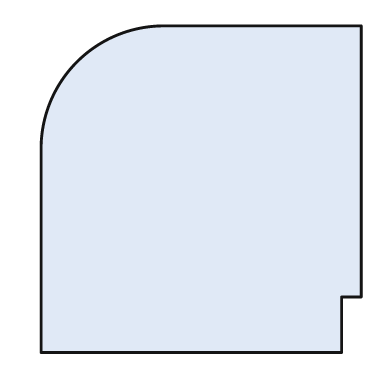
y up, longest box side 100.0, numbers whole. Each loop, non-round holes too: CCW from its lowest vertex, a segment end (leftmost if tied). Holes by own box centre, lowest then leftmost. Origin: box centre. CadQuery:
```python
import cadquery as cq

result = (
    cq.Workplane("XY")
    .moveTo(-49.0, -50.0)
    .lineTo(43.0, -50.0)
    .lineTo(43.0, -33.0)
    .lineTo(49.0, -33.0)
    .lineTo(49.0, 50.0)
    .lineTo(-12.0, 50.0)
    .threePointArc((-38.0, 39.0), (-49.0, 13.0))
    .close()
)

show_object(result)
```